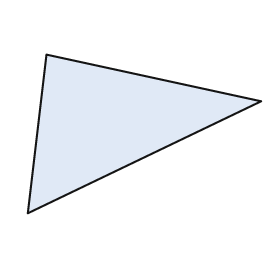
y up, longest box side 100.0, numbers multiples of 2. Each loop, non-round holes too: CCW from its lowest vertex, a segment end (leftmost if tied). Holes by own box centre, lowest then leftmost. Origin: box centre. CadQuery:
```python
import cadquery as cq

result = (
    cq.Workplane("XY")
    .moveTo(-50.0, -34.0)
    .lineTo(50.0, 14.0)
    .lineTo(-42.0, 34.0)
    .close()
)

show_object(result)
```